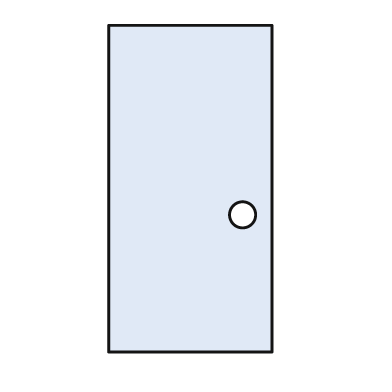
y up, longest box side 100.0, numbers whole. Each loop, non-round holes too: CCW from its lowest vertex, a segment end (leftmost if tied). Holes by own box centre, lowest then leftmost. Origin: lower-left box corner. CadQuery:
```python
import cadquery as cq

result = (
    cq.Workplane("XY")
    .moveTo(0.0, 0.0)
    .lineTo(50.0, 0.0)
    .lineTo(50.0, 100.0)
    .lineTo(0.0, 100.0)
    .close()
    .moveTo(41.0, 42.0)
    .circle(4.0)
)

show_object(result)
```